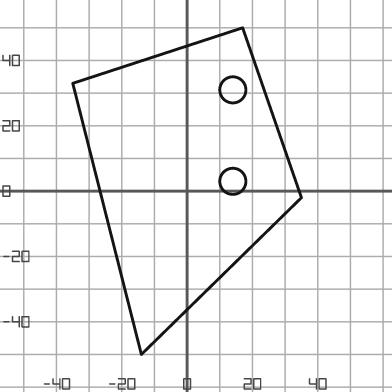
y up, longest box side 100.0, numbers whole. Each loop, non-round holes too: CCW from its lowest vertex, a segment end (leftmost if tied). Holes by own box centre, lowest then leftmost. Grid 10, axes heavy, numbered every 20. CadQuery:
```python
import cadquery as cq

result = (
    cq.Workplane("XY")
    .moveTo(-14.0, -50.0)
    .lineTo(35.0, -2.0)
    .lineTo(17.0, 50.0)
    .lineTo(-35.0, 33.0)
    .close()
    .moveTo(14.0, 3.0)
    .circle(4.0)
    .moveTo(14.0, 31.0)
    .circle(4.0)
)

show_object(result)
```